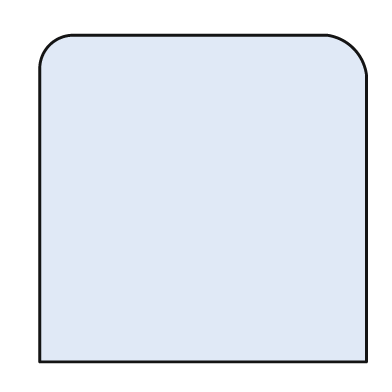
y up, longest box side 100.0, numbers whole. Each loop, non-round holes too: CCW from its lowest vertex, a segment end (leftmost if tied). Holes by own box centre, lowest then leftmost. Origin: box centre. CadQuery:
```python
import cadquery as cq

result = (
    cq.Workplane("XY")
    .moveTo(-50.0, -50.0)
    .lineTo(50.0, -50.0)
    .lineTo(50.0, 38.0)
    .threePointArc((46.0, 46.0), (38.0, 50.0))
    .lineTo(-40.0, 50.0)
    .threePointArc((-47.0, 47.0), (-50.0, 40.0))
    .close()
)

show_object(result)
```